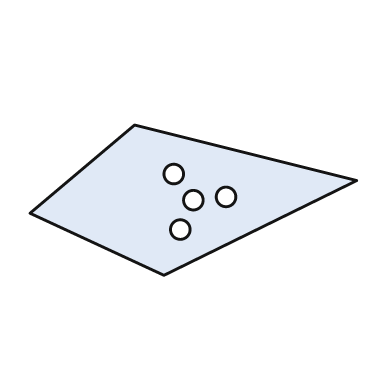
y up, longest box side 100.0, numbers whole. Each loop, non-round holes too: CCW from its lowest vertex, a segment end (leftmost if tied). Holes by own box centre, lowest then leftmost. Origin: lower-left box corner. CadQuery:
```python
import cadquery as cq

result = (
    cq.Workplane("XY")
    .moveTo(41.0, 0.0)
    .lineTo(100.0, 29.0)
    .lineTo(32.0, 46.0)
    .lineTo(0.0, 19.0)
    .close()
    .moveTo(46.0, 14.0)
    .circle(3.0)
    .moveTo(50.0, 23.0)
    .circle(3.0)
    .moveTo(60.0, 24.0)
    .circle(3.0)
    .moveTo(44.0, 31.0)
    .circle(3.0)
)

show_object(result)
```